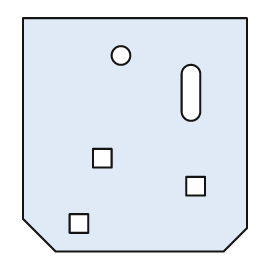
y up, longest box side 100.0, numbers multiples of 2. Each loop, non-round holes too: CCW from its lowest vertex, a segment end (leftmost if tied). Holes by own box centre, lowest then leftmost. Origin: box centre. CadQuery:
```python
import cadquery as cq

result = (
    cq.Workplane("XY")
    .moveTo(-34.0, -50.0)
    .lineTo(38.0, -50.0)
    .lineTo(48.0, -40.0)
    .lineTo(48.0, 50.0)
    .lineTo(-48.0, 50.0)
    .lineTo(-48.0, -36.0)
    .close()
    .moveTo(-28.0, -42.0)
    .lineTo(-20.0, -42.0)
    .lineTo(-20.0, -34.0)
    .lineTo(-28.0, -34.0)
    .close()
    .moveTo(22.0, -26.0)
    .lineTo(30.0, -26.0)
    .lineTo(30.0, -18.0)
    .lineTo(22.0, -18.0)
    .close()
    .moveTo(-18.0, -14.0)
    .lineTo(-10.0, -14.0)
    .lineTo(-10.0, -6.0)
    .lineTo(-18.0, -6.0)
    .close()
    .moveTo(20.0, 10.0)
    .threePointArc((24.0, 6.0), (28.0, 10.0))
    .lineTo(28.0, 26.0)
    .threePointArc((24.0, 30.0), (20.0, 26.0))
    .close()
    .moveTo(-6.0, 34.0)
    .circle(4.0)
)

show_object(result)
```